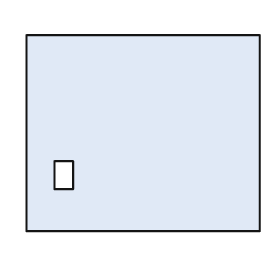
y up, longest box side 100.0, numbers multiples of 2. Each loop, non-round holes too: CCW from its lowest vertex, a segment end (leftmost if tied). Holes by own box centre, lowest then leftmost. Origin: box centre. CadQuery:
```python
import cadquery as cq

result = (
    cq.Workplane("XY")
    .moveTo(-50.0, -42.0)
    .lineTo(50.0, -42.0)
    .lineTo(50.0, 42.0)
    .lineTo(-50.0, 42.0)
    .close()
    .moveTo(-38.0, -24.0)
    .lineTo(-30.0, -24.0)
    .lineTo(-30.0, -12.0)
    .lineTo(-38.0, -12.0)
    .close()
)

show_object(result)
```